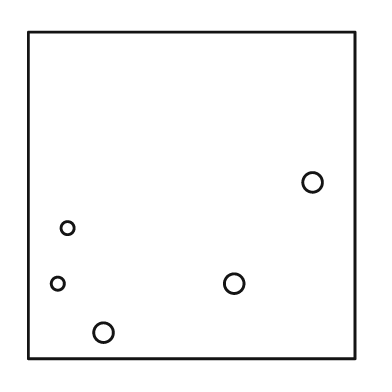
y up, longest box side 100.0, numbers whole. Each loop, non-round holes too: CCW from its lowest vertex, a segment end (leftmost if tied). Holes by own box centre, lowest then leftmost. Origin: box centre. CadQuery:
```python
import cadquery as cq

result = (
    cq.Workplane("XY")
    .moveTo(-50.0, -50.0)
    .lineTo(50.0, -50.0)
    .lineTo(50.0, 50.0)
    .lineTo(-50.0, 50.0)
    .close()
    .moveTo(-27.0, -42.0)
    .circle(3.0)
    .moveTo(-41.0, -27.0)
    .circle(2.0)
    .moveTo(13.0, -27.0)
    .circle(3.0)
    .moveTo(-38.0, -10.0)
    .circle(2.0)
    .moveTo(37.0, 4.0)
    .circle(3.0)
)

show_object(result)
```